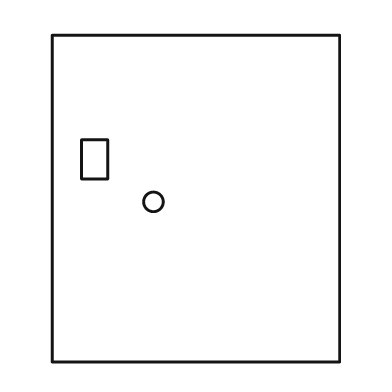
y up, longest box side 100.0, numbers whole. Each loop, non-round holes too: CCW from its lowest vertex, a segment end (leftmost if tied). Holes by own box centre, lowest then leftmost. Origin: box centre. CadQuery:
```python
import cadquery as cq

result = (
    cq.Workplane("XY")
    .moveTo(-44.0, -50.0)
    .lineTo(44.0, -50.0)
    .lineTo(44.0, 50.0)
    .lineTo(-44.0, 50.0)
    .close()
    .moveTo(-13.0, -1.0)
    .circle(3.0)
    .moveTo(-35.0, 6.0)
    .lineTo(-27.0, 6.0)
    .lineTo(-27.0, 18.0)
    .lineTo(-35.0, 18.0)
    .close()
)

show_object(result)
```